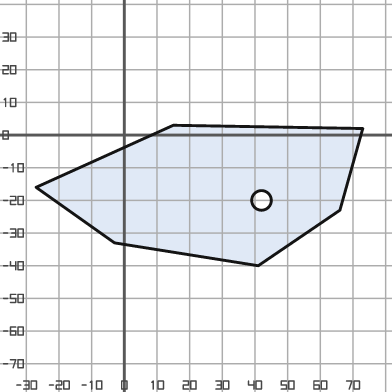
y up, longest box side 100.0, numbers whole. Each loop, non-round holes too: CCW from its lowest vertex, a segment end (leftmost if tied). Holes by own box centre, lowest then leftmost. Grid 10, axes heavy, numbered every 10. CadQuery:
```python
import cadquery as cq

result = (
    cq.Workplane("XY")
    .moveTo(41.0, -40.0)
    .lineTo(66.0, -23.0)
    .lineTo(73.0, 2.0)
    .lineTo(15.0, 3.0)
    .lineTo(-27.0, -16.0)
    .lineTo(-3.0, -33.0)
    .close()
    .moveTo(42.0, -20.0)
    .circle(3.0)
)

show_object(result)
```